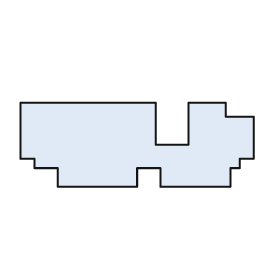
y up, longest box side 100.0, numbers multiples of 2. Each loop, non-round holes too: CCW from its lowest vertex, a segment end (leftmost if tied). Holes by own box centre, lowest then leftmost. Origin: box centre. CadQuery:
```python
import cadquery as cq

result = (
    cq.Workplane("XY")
    .moveTo(-34.0, -18.0)
    .lineTo(0.0, -18.0)
    .lineTo(0.0, -10.0)
    .lineTo(10.0, -10.0)
    .lineTo(10.0, -18.0)
    .lineTo(40.0, -18.0)
    .lineTo(40.0, -10.0)
    .lineTo(44.0, -10.0)
    .lineTo(44.0, -6.0)
    .lineTo(50.0, -6.0)
    .lineTo(50.0, 12.0)
    .lineTo(38.0, 12.0)
    .lineTo(38.0, 18.0)
    .lineTo(22.0, 18.0)
    .lineTo(22.0, 0.0)
    .lineTo(8.0, 0.0)
    .lineTo(8.0, 18.0)
    .lineTo(-50.0, 18.0)
    .lineTo(-50.0, -6.0)
    .lineTo(-44.0, -6.0)
    .lineTo(-44.0, -10.0)
    .lineTo(-34.0, -10.0)
    .close()
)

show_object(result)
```